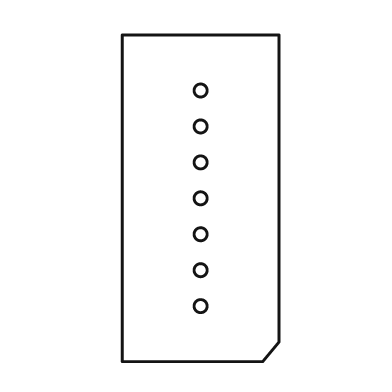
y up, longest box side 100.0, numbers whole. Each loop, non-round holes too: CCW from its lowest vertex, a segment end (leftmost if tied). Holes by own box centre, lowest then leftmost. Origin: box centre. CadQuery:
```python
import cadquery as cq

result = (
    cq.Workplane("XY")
    .moveTo(-24.0, -50.0)
    .lineTo(19.0, -50.0)
    .lineTo(24.0, -44.0)
    .lineTo(24.0, 50.0)
    .lineTo(-24.0, 50.0)
    .close()
    .moveTo(0.0, -33.0)
    .circle(2.0)
    .moveTo(0.0, -22.0)
    .circle(2.0)
    .moveTo(0.0, -11.0)
    .circle(2.0)
    .moveTo(0.0, 0.0)
    .circle(2.0)
    .moveTo(0.0, 11.0)
    .circle(2.0)
    .moveTo(0.0, 22.0)
    .circle(2.0)
    .moveTo(0.0, 33.0)
    .circle(2.0)
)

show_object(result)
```